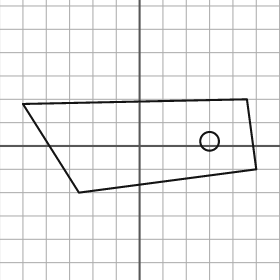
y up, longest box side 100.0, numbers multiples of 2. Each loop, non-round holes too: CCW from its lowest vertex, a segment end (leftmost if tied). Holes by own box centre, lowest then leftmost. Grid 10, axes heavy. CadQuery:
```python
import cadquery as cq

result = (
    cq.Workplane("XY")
    .moveTo(-26.0, -20.0)
    .lineTo(50.0, -10.0)
    .lineTo(46.0, 20.0)
    .lineTo(-50.0, 18.0)
    .close()
    .moveTo(30.0, 2.0)
    .circle(4.0)
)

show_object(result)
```